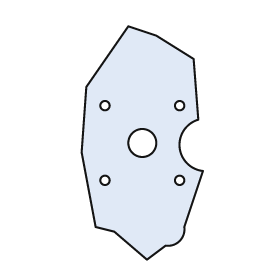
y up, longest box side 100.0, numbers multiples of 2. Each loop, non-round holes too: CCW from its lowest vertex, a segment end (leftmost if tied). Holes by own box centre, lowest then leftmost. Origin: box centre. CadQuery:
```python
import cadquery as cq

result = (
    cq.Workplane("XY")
    .moveTo(2.0, -50.0)
    .lineTo(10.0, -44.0)
    .threePointArc((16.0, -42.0), (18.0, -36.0))
    .lineTo(26.0, -12.0)
    .threePointArc((16.0, -2.0), (24.0, 10.0))
    .lineTo(22.0, 36.0)
    .lineTo(6.0, 46.0)
    .lineTo(-6.0, 50.0)
    .lineTo(-24.0, 24.0)
    .lineTo(-26.0, -4.0)
    .lineTo(-20.0, -36.0)
    .lineTo(-12.0, -38.0)
    .close()
    .moveTo(-16.0, -16.0)
    .circle(2.0)
    .moveTo(16.0, -16.0)
    .circle(2.0)
    .moveTo(0.0, 0.0)
    .circle(6.0)
    .moveTo(-16.0, 16.0)
    .circle(2.0)
    .moveTo(16.0, 16.0)
    .circle(2.0)
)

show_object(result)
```